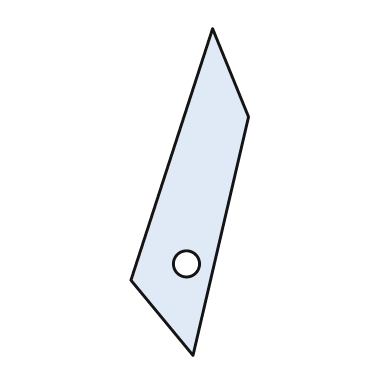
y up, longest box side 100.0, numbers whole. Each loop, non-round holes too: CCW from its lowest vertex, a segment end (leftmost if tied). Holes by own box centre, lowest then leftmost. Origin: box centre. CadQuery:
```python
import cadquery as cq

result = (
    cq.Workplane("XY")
    .moveTo(1.0, -50.0)
    .lineTo(18.0, 23.0)
    .lineTo(7.0, 50.0)
    .lineTo(-18.0, -27.0)
    .close()
    .moveTo(-1.0, -22.0)
    .circle(4.0)
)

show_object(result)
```